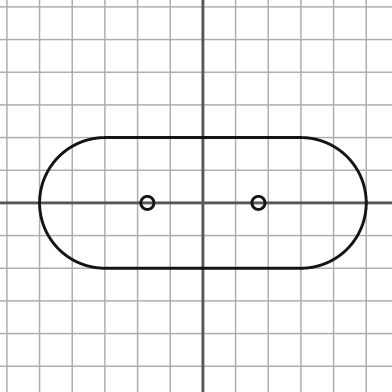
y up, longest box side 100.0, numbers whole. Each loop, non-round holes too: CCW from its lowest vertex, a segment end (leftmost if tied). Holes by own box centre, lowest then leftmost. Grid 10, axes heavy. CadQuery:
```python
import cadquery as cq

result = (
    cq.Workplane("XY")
    .moveTo(-30.0, -20.0)
    .lineTo(30.0, -20.0)
    .threePointArc((50.0, 0.0), (30.0, 20.0))
    .lineTo(-30.0, 20.0)
    .threePointArc((-50.0, 0.0), (-30.0, -20.0))
    .close()
    .moveTo(-17.0, 0.0)
    .circle(2.0)
    .moveTo(17.0, 0.0)
    .circle(2.0)
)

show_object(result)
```